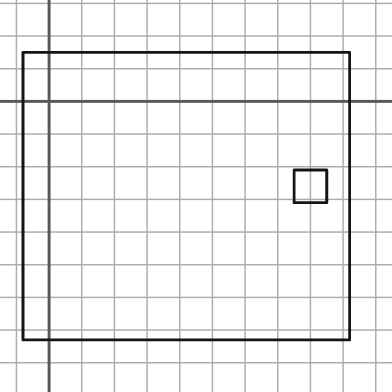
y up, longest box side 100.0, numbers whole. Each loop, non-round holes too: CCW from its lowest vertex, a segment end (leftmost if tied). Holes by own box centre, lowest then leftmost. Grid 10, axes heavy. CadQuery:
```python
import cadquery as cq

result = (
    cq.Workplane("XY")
    .moveTo(-8.0, -73.0)
    .lineTo(92.0, -73.0)
    .lineTo(92.0, 15.0)
    .lineTo(-8.0, 15.0)
    .close()
    .moveTo(75.0, -31.0)
    .lineTo(85.0, -31.0)
    .lineTo(85.0, -21.0)
    .lineTo(75.0, -21.0)
    .close()
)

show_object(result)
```